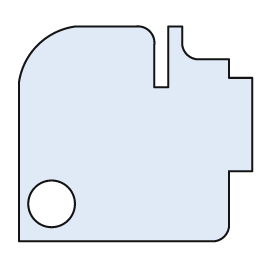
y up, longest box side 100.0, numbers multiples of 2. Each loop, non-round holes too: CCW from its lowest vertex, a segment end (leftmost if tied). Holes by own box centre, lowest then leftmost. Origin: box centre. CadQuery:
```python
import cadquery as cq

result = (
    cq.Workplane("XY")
    .moveTo(-50.0, -46.0)
    .lineTo(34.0, -46.0)
    .threePointArc((38.0, -44.0), (40.0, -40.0))
    .lineTo(40.0, -16.0)
    .lineTo(50.0, -16.0)
    .lineTo(50.0, 24.0)
    .lineTo(40.0, 24.0)
    .lineTo(40.0, 32.0)
    .lineTo(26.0, 32.0)
    .threePointArc((22.0, 34.0), (20.0, 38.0))
    .lineTo(20.0, 46.0)
    .lineTo(14.0, 46.0)
    .lineTo(14.0, 20.0)
    .lineTo(8.0, 20.0)
    .lineTo(8.0, 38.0)
    .threePointArc((6.0, 44.0), (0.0, 46.0))
    .lineTo(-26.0, 46.0)
    .threePointArc((-42.0, 38.0), (-50.0, 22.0))
    .close()
    .moveTo(-36.0, -30.0)
    .circle(10.0)
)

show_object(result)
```